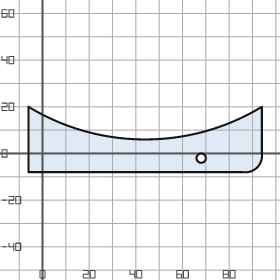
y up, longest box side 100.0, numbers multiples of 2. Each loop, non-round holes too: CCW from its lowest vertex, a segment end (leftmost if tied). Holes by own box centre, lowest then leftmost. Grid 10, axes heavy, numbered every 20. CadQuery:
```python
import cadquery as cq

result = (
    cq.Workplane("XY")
    .moveTo(-6.0, -8.0)
    .lineTo(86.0, -8.0)
    .threePointArc((92.0, -6.0), (94.0, 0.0))
    .lineTo(94.0, 20.0)
    .threePointArc((44.0, 6.0), (-6.0, 20.0))
    .close()
    .moveTo(68.0, -2.0)
    .circle(2.0)
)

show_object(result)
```